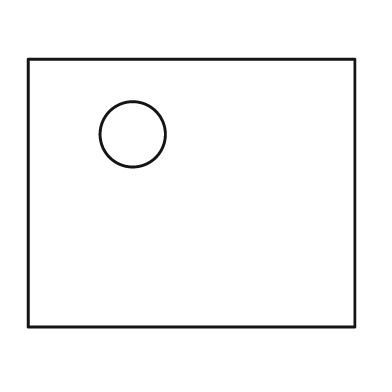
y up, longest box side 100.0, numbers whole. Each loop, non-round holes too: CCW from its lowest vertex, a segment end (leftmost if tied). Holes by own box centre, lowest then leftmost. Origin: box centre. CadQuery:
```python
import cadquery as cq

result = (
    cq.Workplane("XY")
    .moveTo(-50.0, -41.0)
    .lineTo(50.0, -41.0)
    .lineTo(50.0, 41.0)
    .lineTo(-50.0, 41.0)
    .close()
    .moveTo(-18.0, 18.0)
    .circle(10.0)
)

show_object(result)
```